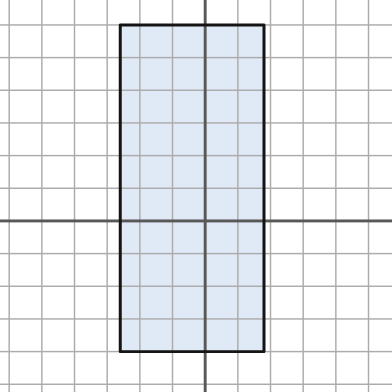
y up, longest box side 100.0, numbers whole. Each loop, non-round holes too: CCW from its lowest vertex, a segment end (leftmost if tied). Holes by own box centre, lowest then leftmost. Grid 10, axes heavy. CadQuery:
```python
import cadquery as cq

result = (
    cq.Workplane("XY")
    .moveTo(-26.0, -40.0)
    .lineTo(18.0, -40.0)
    .lineTo(18.0, 60.0)
    .lineTo(-26.0, 60.0)
    .close()
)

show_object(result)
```